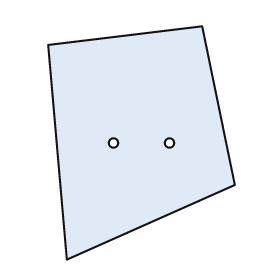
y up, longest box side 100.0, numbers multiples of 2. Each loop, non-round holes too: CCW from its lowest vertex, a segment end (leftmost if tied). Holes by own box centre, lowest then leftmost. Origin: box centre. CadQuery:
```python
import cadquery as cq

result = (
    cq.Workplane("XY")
    .moveTo(-32.0, -50.0)
    .lineTo(40.0, -18.0)
    .lineTo(26.0, 50.0)
    .lineTo(-40.0, 42.0)
    .close()
    .moveTo(-12.0, 0.0)
    .circle(2.0)
    .moveTo(12.0, 0.0)
    .circle(2.0)
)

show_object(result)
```